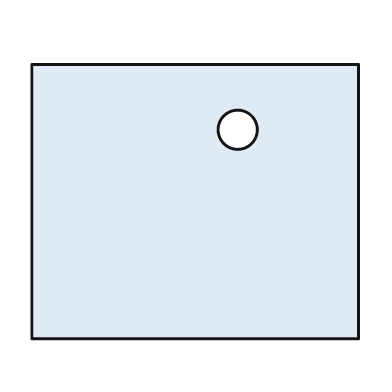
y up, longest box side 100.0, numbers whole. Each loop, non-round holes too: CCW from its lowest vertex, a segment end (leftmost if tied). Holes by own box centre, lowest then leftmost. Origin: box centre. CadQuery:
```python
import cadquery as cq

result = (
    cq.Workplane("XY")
    .moveTo(-50.0, -42.0)
    .lineTo(50.0, -42.0)
    .lineTo(50.0, 42.0)
    .lineTo(-50.0, 42.0)
    .close()
    .moveTo(13.0, 22.0)
    .circle(6.0)
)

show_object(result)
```